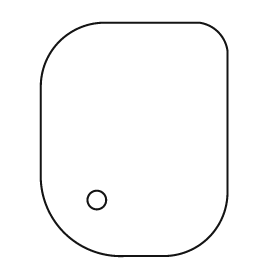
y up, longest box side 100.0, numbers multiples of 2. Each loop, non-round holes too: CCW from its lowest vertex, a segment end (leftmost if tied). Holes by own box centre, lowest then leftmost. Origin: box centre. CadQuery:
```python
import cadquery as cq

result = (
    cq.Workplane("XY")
    .moveTo(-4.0, -50.0)
    .lineTo(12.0, -50.0)
    .threePointArc((32.0, -42.0), (40.0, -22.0))
    .lineTo(40.0, 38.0)
    .threePointArc((36.0, 46.0), (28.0, 50.0))
    .lineTo(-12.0, 50.0)
    .threePointArc((-32.0, 42.0), (-40.0, 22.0))
    .lineTo(-40.0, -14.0)
    .threePointArc((-30.0, -40.0), (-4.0, -50.0))
    .close()
    .moveTo(-16.0, -26.0)
    .circle(4.0)
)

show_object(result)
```